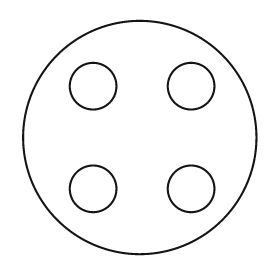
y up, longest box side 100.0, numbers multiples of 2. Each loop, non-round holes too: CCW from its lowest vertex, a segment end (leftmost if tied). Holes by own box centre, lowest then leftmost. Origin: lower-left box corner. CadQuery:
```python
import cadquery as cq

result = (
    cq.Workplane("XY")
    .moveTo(50.0, 50.0)
    .circle(50.0)
    .moveTo(30.0, 28.0)
    .circle(10.0)
    .moveTo(72.0, 28.0)
    .circle(10.0)
    .moveTo(30.0, 72.0)
    .circle(10.0)
    .moveTo(72.0, 72.0)
    .circle(10.0)
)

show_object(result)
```